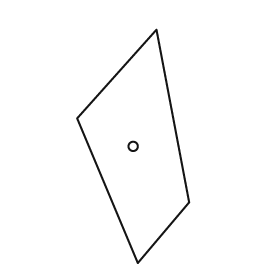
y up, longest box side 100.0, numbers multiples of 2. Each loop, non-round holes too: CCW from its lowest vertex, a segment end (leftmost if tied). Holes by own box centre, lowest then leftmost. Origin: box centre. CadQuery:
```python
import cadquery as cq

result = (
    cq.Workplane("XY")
    .moveTo(2.0, -50.0)
    .lineTo(24.0, -24.0)
    .lineTo(10.0, 50.0)
    .lineTo(-24.0, 12.0)
    .close()
    .moveTo(0.0, 0.0)
    .circle(2.0)
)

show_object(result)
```